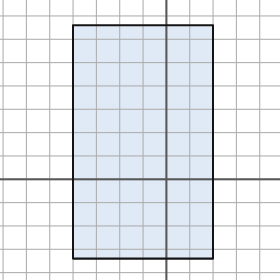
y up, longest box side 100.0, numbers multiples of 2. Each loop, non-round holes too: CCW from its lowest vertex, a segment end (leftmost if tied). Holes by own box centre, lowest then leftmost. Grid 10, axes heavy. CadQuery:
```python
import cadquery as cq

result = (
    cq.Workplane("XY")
    .moveTo(-40.0, -34.0)
    .lineTo(20.0, -34.0)
    .lineTo(20.0, 66.0)
    .lineTo(-40.0, 66.0)
    .close()
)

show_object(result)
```